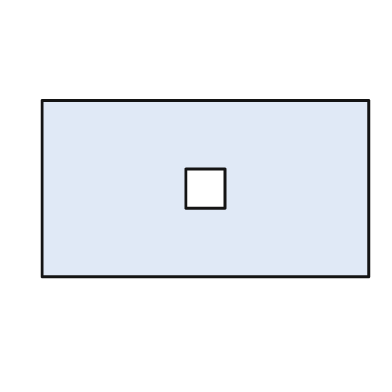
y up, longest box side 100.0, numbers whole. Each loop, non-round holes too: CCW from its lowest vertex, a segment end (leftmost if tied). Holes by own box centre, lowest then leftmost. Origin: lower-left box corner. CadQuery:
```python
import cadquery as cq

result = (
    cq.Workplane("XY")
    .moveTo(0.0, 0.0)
    .lineTo(100.0, 0.0)
    .lineTo(100.0, 54.0)
    .lineTo(0.0, 54.0)
    .close()
    .moveTo(44.0, 21.0)
    .lineTo(56.0, 21.0)
    .lineTo(56.0, 33.0)
    .lineTo(44.0, 33.0)
    .close()
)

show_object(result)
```